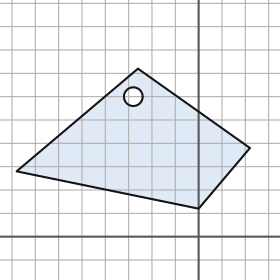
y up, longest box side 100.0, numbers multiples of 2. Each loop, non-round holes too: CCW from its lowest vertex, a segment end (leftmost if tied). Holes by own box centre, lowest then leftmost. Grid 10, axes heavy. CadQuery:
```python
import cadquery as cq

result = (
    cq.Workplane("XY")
    .moveTo(0.0, 12.0)
    .lineTo(22.0, 38.0)
    .lineTo(-26.0, 72.0)
    .lineTo(-78.0, 28.0)
    .close()
    .moveTo(-28.0, 60.0)
    .circle(4.0)
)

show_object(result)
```